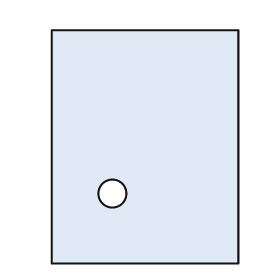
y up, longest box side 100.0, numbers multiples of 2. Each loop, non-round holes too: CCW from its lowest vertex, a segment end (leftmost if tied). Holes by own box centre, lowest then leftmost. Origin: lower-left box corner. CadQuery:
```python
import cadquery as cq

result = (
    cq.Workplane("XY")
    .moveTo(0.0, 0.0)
    .lineTo(80.0, 0.0)
    .lineTo(80.0, 100.0)
    .lineTo(0.0, 100.0)
    .close()
    .moveTo(26.0, 30.0)
    .circle(6.0)
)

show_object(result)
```